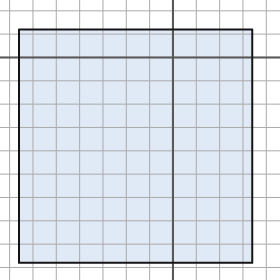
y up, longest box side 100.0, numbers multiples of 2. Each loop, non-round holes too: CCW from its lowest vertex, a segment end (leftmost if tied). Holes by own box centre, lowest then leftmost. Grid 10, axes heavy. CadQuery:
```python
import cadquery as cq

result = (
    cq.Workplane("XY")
    .moveTo(-66.0, -88.0)
    .lineTo(34.0, -88.0)
    .lineTo(34.0, 12.0)
    .lineTo(-66.0, 12.0)
    .close()
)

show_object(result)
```